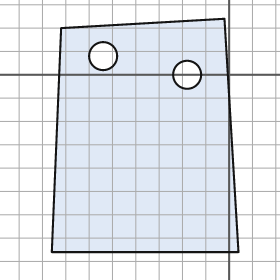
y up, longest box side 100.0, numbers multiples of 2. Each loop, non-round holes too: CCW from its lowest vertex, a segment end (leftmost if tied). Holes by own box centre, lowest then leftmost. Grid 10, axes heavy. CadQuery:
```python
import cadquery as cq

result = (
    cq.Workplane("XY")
    .moveTo(-76.0, -76.0)
    .lineTo(4.0, -76.0)
    .lineTo(-2.0, 24.0)
    .lineTo(-72.0, 20.0)
    .close()
    .moveTo(-18.0, 0.0)
    .circle(6.0)
    .moveTo(-54.0, 8.0)
    .circle(6.0)
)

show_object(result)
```